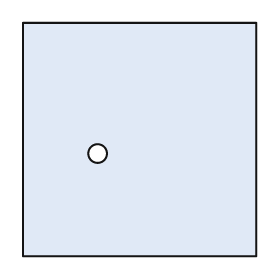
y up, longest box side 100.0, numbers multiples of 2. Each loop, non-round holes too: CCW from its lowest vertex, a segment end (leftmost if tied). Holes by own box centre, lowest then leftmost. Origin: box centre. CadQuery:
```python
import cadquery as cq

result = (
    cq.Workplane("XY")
    .moveTo(-50.0, -50.0)
    .lineTo(50.0, -50.0)
    .lineTo(50.0, 50.0)
    .lineTo(-50.0, 50.0)
    .close()
    .moveTo(-18.0, -6.0)
    .circle(4.0)
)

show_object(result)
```